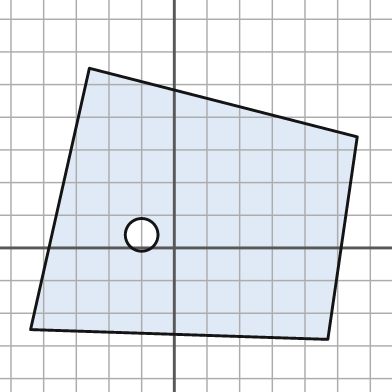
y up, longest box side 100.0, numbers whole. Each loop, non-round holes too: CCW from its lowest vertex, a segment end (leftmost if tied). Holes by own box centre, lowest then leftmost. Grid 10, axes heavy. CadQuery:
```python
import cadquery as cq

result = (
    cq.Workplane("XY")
    .moveTo(47.0, -28.0)
    .lineTo(56.0, 34.0)
    .lineTo(-26.0, 55.0)
    .lineTo(-44.0, -25.0)
    .close()
    .moveTo(-10.0, 4.0)
    .circle(5.0)
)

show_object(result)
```